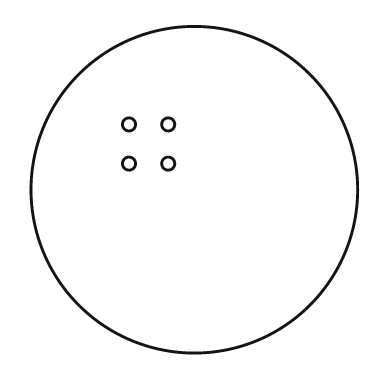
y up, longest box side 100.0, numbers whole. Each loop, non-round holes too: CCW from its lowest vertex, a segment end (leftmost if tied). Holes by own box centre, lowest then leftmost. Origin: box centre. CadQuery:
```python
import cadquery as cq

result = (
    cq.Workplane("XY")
    .moveTo(0.0, 0.0)
    .circle(50.0)
    .moveTo(-20.0, 8.0)
    .circle(2.0)
    .moveTo(-8.0, 8.0)
    .circle(2.0)
    .moveTo(-20.0, 20.0)
    .circle(2.0)
    .moveTo(-8.0, 20.0)
    .circle(2.0)
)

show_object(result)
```